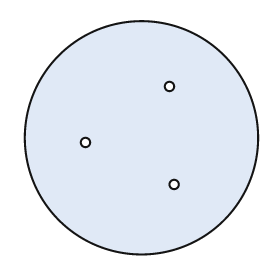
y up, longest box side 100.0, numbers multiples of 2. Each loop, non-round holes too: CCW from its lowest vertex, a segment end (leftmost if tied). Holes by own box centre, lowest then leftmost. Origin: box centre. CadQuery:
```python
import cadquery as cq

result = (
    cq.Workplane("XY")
    .moveTo(0.0, 0.0)
    .circle(50.0)
    .moveTo(14.0, -20.0)
    .circle(2.0)
    .moveTo(-24.0, -2.0)
    .circle(2.0)
    .moveTo(12.0, 22.0)
    .circle(2.0)
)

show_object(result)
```